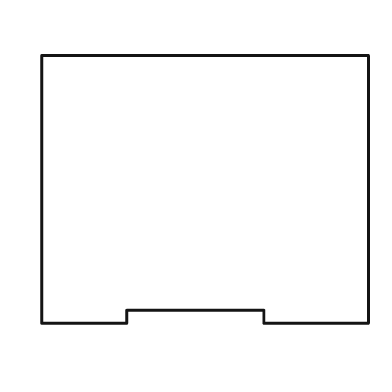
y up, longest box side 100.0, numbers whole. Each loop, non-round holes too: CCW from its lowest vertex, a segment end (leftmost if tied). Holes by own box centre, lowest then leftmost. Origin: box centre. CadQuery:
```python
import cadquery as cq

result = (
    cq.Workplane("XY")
    .moveTo(-50.0, -41.0)
    .lineTo(-24.0, -41.0)
    .lineTo(-24.0, -37.0)
    .lineTo(18.0, -37.0)
    .lineTo(18.0, -41.0)
    .lineTo(50.0, -41.0)
    .lineTo(50.0, 41.0)
    .lineTo(-50.0, 41.0)
    .close()
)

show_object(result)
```